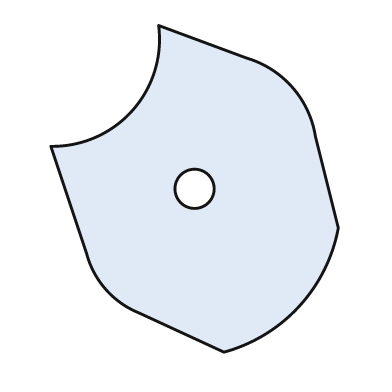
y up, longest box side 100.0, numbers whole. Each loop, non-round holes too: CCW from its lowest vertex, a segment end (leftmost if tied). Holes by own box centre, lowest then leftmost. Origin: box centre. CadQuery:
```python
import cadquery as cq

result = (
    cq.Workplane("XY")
    .moveTo(9.0, -50.0)
    .threePointArc((32.0, -36.0), (44.0, -12.0))
    .lineTo(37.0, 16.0)
    .threePointArc((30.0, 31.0), (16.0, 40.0))
    .lineTo(-11.0, 50.0)
    .threePointArc((-19.0, 24.0), (-44.0, 13.0))
    .lineTo(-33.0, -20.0)
    .threePointArc((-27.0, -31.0), (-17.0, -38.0))
    .close()
    .moveTo(0.0, 0.0)
    .circle(6.0)
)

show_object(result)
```